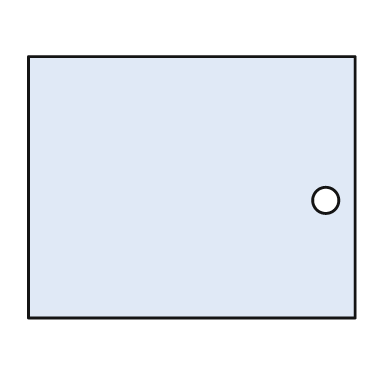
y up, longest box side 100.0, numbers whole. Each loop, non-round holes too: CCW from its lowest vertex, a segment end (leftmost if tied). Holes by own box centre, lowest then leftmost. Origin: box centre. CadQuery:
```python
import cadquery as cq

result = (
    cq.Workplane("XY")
    .moveTo(-50.0, -40.0)
    .lineTo(50.0, -40.0)
    .lineTo(50.0, 40.0)
    .lineTo(-50.0, 40.0)
    .close()
    .moveTo(41.0, -4.0)
    .circle(4.0)
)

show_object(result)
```